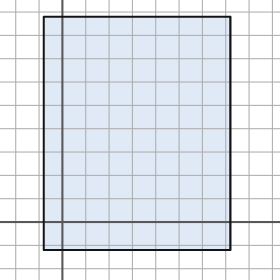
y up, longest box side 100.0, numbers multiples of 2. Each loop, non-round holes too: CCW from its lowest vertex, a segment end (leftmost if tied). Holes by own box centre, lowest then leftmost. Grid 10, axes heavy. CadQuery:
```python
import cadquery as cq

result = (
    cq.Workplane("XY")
    .moveTo(-8.0, -12.0)
    .lineTo(72.0, -12.0)
    .lineTo(72.0, 88.0)
    .lineTo(-8.0, 88.0)
    .close()
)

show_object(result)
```